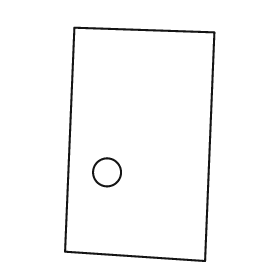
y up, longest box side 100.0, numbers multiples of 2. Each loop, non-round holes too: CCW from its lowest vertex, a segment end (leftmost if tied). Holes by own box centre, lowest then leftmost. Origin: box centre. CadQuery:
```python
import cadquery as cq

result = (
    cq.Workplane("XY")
    .moveTo(28.0, -50.0)
    .lineTo(32.0, 48.0)
    .lineTo(-28.0, 50.0)
    .lineTo(-32.0, -46.0)
    .close()
    .moveTo(-14.0, -12.0)
    .circle(6.0)
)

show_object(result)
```